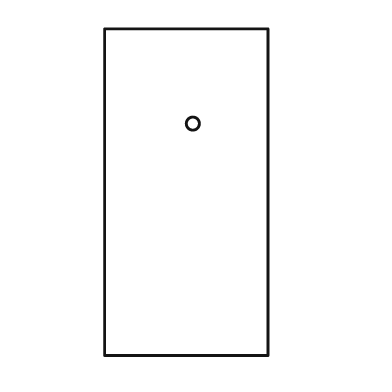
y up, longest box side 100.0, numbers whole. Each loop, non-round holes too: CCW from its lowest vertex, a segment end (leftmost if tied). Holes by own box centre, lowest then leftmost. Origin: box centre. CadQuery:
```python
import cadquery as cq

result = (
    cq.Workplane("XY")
    .moveTo(-25.0, -50.0)
    .lineTo(25.0, -50.0)
    .lineTo(25.0, 50.0)
    .lineTo(-25.0, 50.0)
    .close()
    .moveTo(2.0, 21.0)
    .circle(2.0)
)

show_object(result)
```